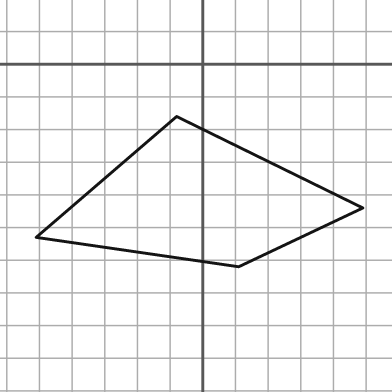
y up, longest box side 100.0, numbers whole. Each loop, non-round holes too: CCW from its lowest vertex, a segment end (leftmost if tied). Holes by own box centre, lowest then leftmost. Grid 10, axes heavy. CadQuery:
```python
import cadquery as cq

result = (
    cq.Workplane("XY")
    .moveTo(11.0, -62.0)
    .lineTo(49.0, -44.0)
    .lineTo(-8.0, -16.0)
    .lineTo(-51.0, -53.0)
    .close()
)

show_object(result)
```